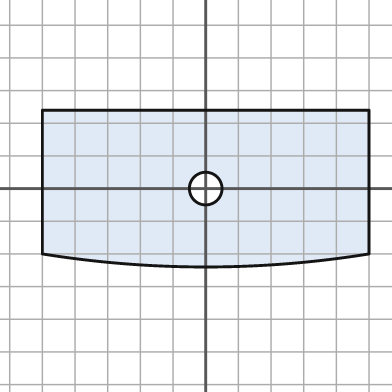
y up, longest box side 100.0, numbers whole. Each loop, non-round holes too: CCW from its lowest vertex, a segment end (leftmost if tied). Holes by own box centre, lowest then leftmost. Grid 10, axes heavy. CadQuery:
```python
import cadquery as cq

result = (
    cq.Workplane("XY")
    .moveTo(-50.0, -20.0)
    .threePointArc((0.0, -24.0), (50.0, -20.0))
    .lineTo(50.0, 24.0)
    .lineTo(-50.0, 24.0)
    .close()
    .moveTo(0.0, 0.0)
    .circle(5.0)
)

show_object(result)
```